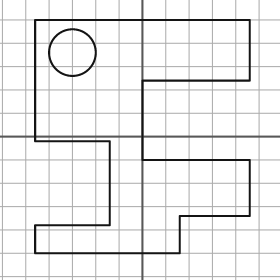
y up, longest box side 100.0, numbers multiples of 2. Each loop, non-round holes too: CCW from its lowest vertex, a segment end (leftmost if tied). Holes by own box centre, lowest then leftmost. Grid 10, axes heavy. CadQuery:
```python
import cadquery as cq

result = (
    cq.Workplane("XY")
    .moveTo(-46.0, -50.0)
    .lineTo(16.0, -50.0)
    .lineTo(16.0, -34.0)
    .lineTo(46.0, -34.0)
    .lineTo(46.0, -10.0)
    .lineTo(0.0, -10.0)
    .lineTo(0.0, 24.0)
    .lineTo(46.0, 24.0)
    .lineTo(46.0, 50.0)
    .lineTo(-46.0, 50.0)
    .lineTo(-46.0, -2.0)
    .lineTo(-14.0, -2.0)
    .lineTo(-14.0, -38.0)
    .lineTo(-46.0, -38.0)
    .close()
    .moveTo(-30.0, 36.0)
    .circle(10.0)
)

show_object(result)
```